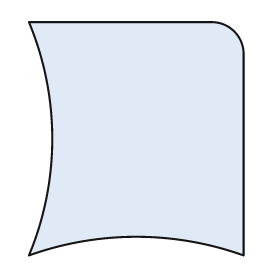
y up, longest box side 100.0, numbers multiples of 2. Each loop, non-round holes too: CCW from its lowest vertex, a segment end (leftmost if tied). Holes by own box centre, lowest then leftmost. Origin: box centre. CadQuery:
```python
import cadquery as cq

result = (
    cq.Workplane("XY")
    .moveTo(-46.0, -50.0)
    .threePointArc((0.0, -42.0), (46.0, -50.0))
    .lineTo(46.0, 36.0)
    .threePointArc((42.0, 46.0), (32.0, 50.0))
    .lineTo(-46.0, 50.0)
    .threePointArc((-36.0, 0.0), (-46.0, -50.0))
    .close()
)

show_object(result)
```